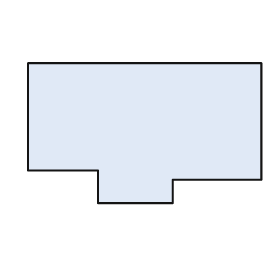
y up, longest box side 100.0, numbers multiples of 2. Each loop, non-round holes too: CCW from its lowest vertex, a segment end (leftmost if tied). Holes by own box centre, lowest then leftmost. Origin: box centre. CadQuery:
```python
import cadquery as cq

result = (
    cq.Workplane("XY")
    .moveTo(-20.0, -30.0)
    .lineTo(12.0, -30.0)
    .lineTo(12.0, -20.0)
    .lineTo(50.0, -20.0)
    .lineTo(50.0, 30.0)
    .lineTo(-50.0, 30.0)
    .lineTo(-50.0, -16.0)
    .lineTo(-20.0, -16.0)
    .close()
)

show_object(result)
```